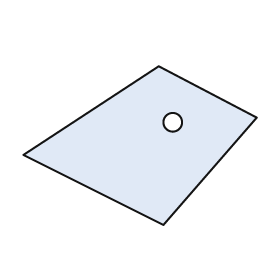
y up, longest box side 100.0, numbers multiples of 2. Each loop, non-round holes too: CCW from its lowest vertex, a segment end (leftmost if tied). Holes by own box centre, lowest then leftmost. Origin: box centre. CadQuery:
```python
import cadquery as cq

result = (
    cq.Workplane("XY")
    .moveTo(10.0, -34.0)
    .lineTo(50.0, 12.0)
    .lineTo(8.0, 34.0)
    .lineTo(-50.0, -4.0)
    .close()
    .moveTo(14.0, 10.0)
    .circle(4.0)
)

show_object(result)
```